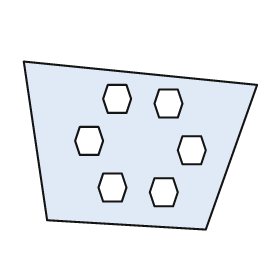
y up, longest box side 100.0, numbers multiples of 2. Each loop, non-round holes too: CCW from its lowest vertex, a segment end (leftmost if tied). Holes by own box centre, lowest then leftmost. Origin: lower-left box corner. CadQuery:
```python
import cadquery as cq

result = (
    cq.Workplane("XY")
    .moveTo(78.0, 0.0)
    .lineTo(100.0, 62.0)
    .lineTo(0.0, 72.0)
    .lineTo(10.0, 4.0)
    .close()
    .moveTo(56.0, 10.0)
    .lineTo(64.0, 10.0)
    .lineTo(66.0, 16.0)
    .lineTo(64.0, 22.0)
    .lineTo(56.0, 22.0)
    .lineTo(54.0, 16.0)
    .close()
    .moveTo(34.0, 12.0)
    .lineTo(42.0, 12.0)
    .lineTo(44.0, 18.0)
    .lineTo(42.0, 24.0)
    .lineTo(34.0, 24.0)
    .lineTo(32.0, 18.0)
    .close()
    .moveTo(68.0, 28.0)
    .lineTo(76.0, 28.0)
    .lineTo(78.0, 34.0)
    .lineTo(76.0, 40.0)
    .lineTo(68.0, 40.0)
    .lineTo(66.0, 34.0)
    .close()
    .moveTo(24.0, 32.0)
    .lineTo(32.0, 32.0)
    .lineTo(34.0, 38.0)
    .lineTo(32.0, 44.0)
    .lineTo(24.0, 44.0)
    .lineTo(22.0, 38.0)
    .close()
    .moveTo(58.0, 48.0)
    .lineTo(66.0, 48.0)
    .lineTo(68.0, 54.0)
    .lineTo(66.0, 60.0)
    .lineTo(58.0, 60.0)
    .lineTo(56.0, 54.0)
    .close()
    .moveTo(36.0, 50.0)
    .lineTo(44.0, 50.0)
    .lineTo(46.0, 56.0)
    .lineTo(44.0, 62.0)
    .lineTo(36.0, 62.0)
    .lineTo(34.0, 56.0)
    .close()
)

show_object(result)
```